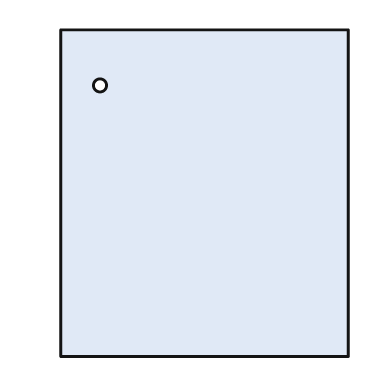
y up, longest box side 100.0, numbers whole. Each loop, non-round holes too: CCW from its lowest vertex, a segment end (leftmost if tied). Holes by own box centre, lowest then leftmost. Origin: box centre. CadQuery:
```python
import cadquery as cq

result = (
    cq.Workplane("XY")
    .moveTo(-44.0, -50.0)
    .lineTo(44.0, -50.0)
    .lineTo(44.0, 50.0)
    .lineTo(-44.0, 50.0)
    .close()
    .moveTo(-32.0, 33.0)
    .circle(2.0)
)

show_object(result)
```